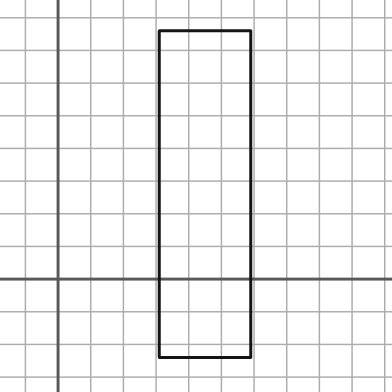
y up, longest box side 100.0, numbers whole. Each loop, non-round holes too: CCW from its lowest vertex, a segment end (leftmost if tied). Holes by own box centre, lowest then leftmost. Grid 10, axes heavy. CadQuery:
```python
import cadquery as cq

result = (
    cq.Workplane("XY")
    .moveTo(31.0, -24.0)
    .lineTo(59.0, -24.0)
    .lineTo(59.0, 76.0)
    .lineTo(31.0, 76.0)
    .close()
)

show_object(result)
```